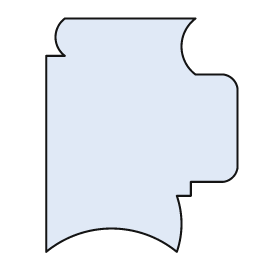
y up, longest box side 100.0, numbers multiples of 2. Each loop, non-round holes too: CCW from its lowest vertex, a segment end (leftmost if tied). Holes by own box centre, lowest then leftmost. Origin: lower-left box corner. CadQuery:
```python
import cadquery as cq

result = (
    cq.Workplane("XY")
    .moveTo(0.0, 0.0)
    .threePointArc((28.0, 10.0), (56.0, 0.0))
    .threePointArc((58.0, 12.0), (56.0, 24.0))
    .lineTo(62.0, 24.0)
    .lineTo(62.0, 30.0)
    .lineTo(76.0, 30.0)
    .threePointArc((80.0, 32.0), (82.0, 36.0))
    .lineTo(82.0, 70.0)
    .threePointArc((80.0, 74.0), (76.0, 76.0))
    .lineTo(64.0, 76.0)
    .threePointArc((58.0, 88.0), (64.0, 100.0))
    .lineTo(8.0, 100.0)
    .threePointArc((4.0, 92.0), (8.0, 84.0))
    .lineTo(0.0, 84.0)
    .close()
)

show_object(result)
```